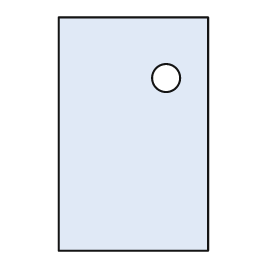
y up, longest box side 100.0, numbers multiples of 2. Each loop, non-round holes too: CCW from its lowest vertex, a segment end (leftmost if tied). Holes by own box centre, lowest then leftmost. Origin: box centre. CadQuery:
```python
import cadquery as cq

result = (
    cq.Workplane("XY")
    .moveTo(-32.0, -50.0)
    .lineTo(32.0, -50.0)
    .lineTo(32.0, 50.0)
    .lineTo(-32.0, 50.0)
    .close()
    .moveTo(14.0, 24.0)
    .circle(6.0)
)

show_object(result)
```